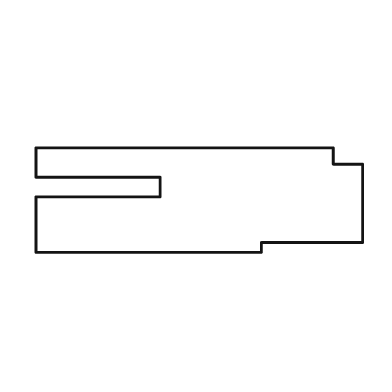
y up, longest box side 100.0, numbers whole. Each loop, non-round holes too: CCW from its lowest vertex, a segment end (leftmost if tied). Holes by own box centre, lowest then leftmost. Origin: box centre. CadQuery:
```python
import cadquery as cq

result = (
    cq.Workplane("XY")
    .moveTo(-50.0, -16.0)
    .lineTo(19.0, -16.0)
    .lineTo(19.0, -13.0)
    .lineTo(50.0, -13.0)
    .lineTo(50.0, 11.0)
    .lineTo(41.0, 11.0)
    .lineTo(41.0, 16.0)
    .lineTo(-50.0, 16.0)
    .lineTo(-50.0, 7.0)
    .lineTo(-12.0, 7.0)
    .lineTo(-12.0, 1.0)
    .lineTo(-50.0, 1.0)
    .close()
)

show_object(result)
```